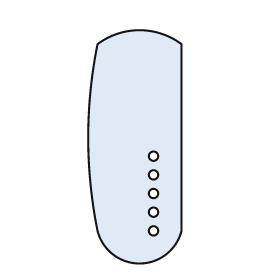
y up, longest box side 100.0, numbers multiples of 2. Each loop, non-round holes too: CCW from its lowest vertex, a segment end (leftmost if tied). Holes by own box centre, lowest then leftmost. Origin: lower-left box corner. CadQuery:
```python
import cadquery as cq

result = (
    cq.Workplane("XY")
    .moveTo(4.0, 14.0)
    .threePointArc((22.0, 0.0), (40.0, 14.0))
    .lineTo(40.0, 94.0)
    .threePointArc((22.0, 100.0), (4.0, 94.0))
    .threePointArc((0.0, 54.0), (4.0, 14.0))
    .close()
    .moveTo(28.0, 14.0)
    .circle(2.0)
    .moveTo(28.0, 22.0)
    .circle(2.0)
    .moveTo(28.0, 30.0)
    .circle(2.0)
    .moveTo(28.0, 38.0)
    .circle(2.0)
    .moveTo(28.0, 46.0)
    .circle(2.0)
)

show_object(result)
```